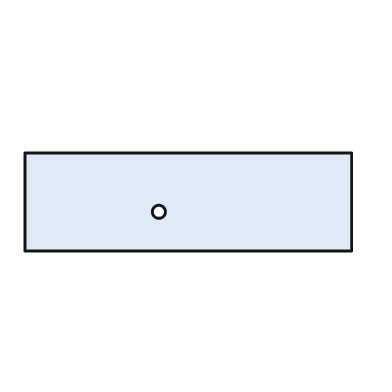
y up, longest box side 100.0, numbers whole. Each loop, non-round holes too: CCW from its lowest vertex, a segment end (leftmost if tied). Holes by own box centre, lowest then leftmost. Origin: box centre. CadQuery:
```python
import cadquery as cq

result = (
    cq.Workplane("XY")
    .moveTo(-50.0, -15.0)
    .lineTo(50.0, -15.0)
    .lineTo(50.0, 15.0)
    .lineTo(-50.0, 15.0)
    .close()
    .moveTo(-9.0, -3.0)
    .circle(2.0)
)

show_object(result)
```